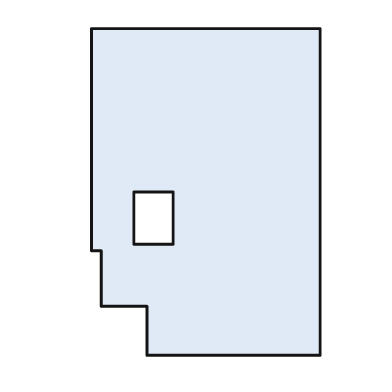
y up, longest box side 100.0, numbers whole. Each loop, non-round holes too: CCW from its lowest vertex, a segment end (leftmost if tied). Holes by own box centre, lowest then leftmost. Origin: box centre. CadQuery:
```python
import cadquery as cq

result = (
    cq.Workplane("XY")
    .moveTo(-18.0, -50.0)
    .lineTo(35.0, -50.0)
    .lineTo(35.0, 50.0)
    .lineTo(-35.0, 50.0)
    .lineTo(-35.0, -18.0)
    .lineTo(-32.0, -18.0)
    .lineTo(-32.0, -35.0)
    .lineTo(-18.0, -35.0)
    .close()
    .moveTo(-22.0, -16.0)
    .lineTo(-10.0, -16.0)
    .lineTo(-10.0, 0.0)
    .lineTo(-22.0, 0.0)
    .close()
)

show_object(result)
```